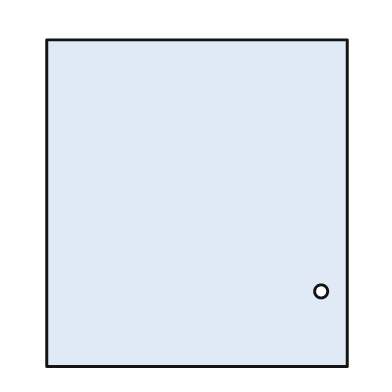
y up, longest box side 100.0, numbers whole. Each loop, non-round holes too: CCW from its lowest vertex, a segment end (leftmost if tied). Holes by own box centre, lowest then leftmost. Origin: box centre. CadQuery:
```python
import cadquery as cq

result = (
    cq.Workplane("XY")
    .moveTo(-46.0, -50.0)
    .lineTo(46.0, -50.0)
    .lineTo(46.0, 50.0)
    .lineTo(-46.0, 50.0)
    .close()
    .moveTo(38.0, -27.0)
    .circle(2.0)
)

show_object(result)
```